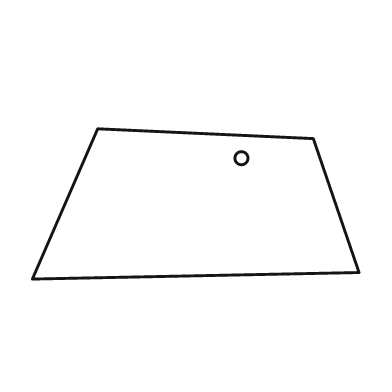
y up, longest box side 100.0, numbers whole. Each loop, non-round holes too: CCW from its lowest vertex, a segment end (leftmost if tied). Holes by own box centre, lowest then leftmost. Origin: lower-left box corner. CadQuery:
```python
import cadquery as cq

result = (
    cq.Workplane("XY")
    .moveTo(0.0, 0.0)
    .lineTo(100.0, 2.0)
    .lineTo(86.0, 43.0)
    .lineTo(20.0, 46.0)
    .close()
    .moveTo(64.0, 37.0)
    .circle(2.0)
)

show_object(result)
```